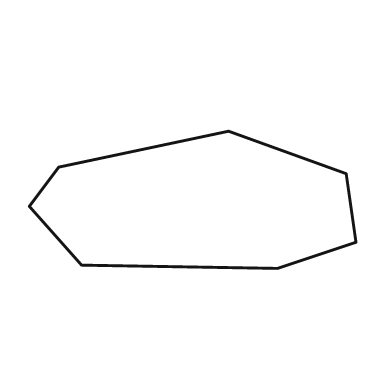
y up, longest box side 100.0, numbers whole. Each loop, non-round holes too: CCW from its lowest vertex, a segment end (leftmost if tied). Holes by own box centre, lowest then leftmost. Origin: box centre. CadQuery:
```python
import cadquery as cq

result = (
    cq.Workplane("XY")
    .moveTo(26.0, -21.0)
    .lineTo(50.0, -13.0)
    .lineTo(47.0, 8.0)
    .lineTo(11.0, 21.0)
    .lineTo(-41.0, 10.0)
    .lineTo(-50.0, -2.0)
    .lineTo(-34.0, -20.0)
    .close()
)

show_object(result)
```